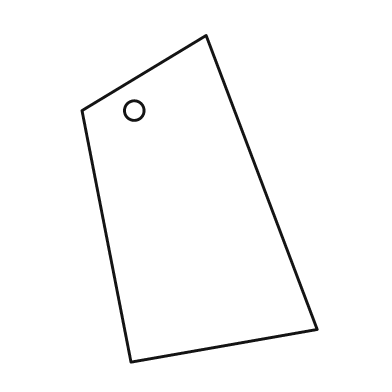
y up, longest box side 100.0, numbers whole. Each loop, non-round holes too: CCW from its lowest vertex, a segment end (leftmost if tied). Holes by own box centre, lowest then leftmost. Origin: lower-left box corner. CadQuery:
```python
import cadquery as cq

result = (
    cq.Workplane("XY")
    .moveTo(15.0, 0.0)
    .lineTo(72.0, 10.0)
    .lineTo(38.0, 100.0)
    .lineTo(0.0, 77.0)
    .close()
    .moveTo(16.0, 77.0)
    .circle(3.0)
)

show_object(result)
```